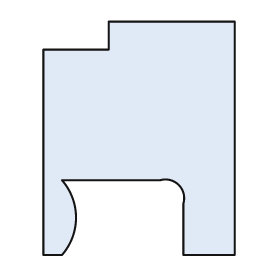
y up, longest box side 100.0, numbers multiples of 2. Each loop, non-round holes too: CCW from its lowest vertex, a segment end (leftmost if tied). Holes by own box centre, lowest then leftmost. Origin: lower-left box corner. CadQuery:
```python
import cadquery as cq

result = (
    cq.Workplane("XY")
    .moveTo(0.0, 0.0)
    .lineTo(8.0, 0.0)
    .threePointArc((14.0, 16.0), (8.0, 32.0))
    .lineTo(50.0, 32.0)
    .threePointArc((58.0, 30.0), (60.0, 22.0))
    .lineTo(60.0, 0.0)
    .lineTo(82.0, 0.0)
    .lineTo(82.0, 100.0)
    .lineTo(28.0, 100.0)
    .lineTo(28.0, 88.0)
    .lineTo(0.0, 88.0)
    .close()
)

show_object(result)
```